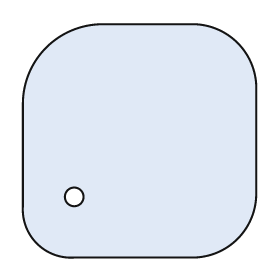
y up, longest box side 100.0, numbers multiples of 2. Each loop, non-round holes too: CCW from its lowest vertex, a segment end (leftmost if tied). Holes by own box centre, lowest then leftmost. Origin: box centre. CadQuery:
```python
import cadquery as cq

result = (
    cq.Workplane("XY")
    .moveTo(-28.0, -50.0)
    .lineTo(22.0, -50.0)
    .threePointArc((42.0, -42.0), (50.0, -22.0))
    .lineTo(50.0, 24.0)
    .threePointArc((42.0, 42.0), (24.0, 50.0))
    .lineTo(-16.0, 50.0)
    .threePointArc((-40.0, 40.0), (-50.0, 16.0))
    .lineTo(-50.0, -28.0)
    .threePointArc((-44.0, -44.0), (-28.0, -50.0))
    .close()
    .moveTo(-28.0, -24.0)
    .circle(4.0)
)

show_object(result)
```